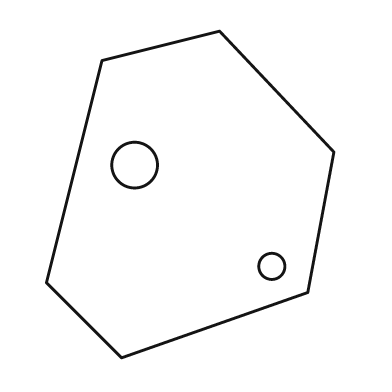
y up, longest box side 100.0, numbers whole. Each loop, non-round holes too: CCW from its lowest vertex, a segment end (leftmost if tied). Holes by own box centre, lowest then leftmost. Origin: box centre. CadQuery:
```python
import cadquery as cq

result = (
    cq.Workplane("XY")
    .moveTo(-21.0, -50.0)
    .lineTo(36.0, -30.0)
    .lineTo(44.0, 13.0)
    .lineTo(9.0, 50.0)
    .lineTo(-27.0, 41.0)
    .lineTo(-44.0, -27.0)
    .close()
    .moveTo(25.0, -22.0)
    .circle(4.0)
    .moveTo(-17.0, 9.0)
    .circle(7.0)
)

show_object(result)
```